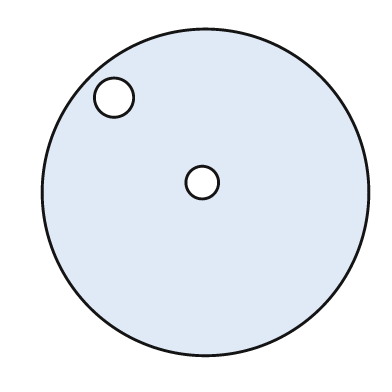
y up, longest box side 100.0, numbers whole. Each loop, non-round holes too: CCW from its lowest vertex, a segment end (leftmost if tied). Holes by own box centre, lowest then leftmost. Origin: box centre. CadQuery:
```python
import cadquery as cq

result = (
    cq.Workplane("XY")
    .moveTo(0.0, 0.0)
    .circle(50.0)
    .moveTo(-1.0, 3.0)
    .circle(5.0)
    .moveTo(-28.0, 29.0)
    .circle(6.0)
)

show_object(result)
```